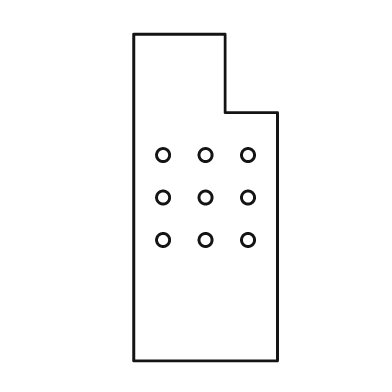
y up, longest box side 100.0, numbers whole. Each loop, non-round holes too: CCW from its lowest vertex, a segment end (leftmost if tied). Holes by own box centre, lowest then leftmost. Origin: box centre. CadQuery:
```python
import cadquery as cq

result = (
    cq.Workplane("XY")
    .moveTo(-22.0, -50.0)
    .lineTo(22.0, -50.0)
    .lineTo(22.0, 26.0)
    .lineTo(6.0, 26.0)
    .lineTo(6.0, 50.0)
    .lineTo(-22.0, 50.0)
    .close()
    .moveTo(-13.0, -13.0)
    .circle(2.0)
    .moveTo(0.0, -13.0)
    .circle(2.0)
    .moveTo(13.0, -13.0)
    .circle(2.0)
    .moveTo(-13.0, 0.0)
    .circle(2.0)
    .moveTo(0.0, 0.0)
    .circle(2.0)
    .moveTo(13.0, 0.0)
    .circle(2.0)
    .moveTo(-13.0, 13.0)
    .circle(2.0)
    .moveTo(0.0, 13.0)
    .circle(2.0)
    .moveTo(13.0, 13.0)
    .circle(2.0)
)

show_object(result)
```